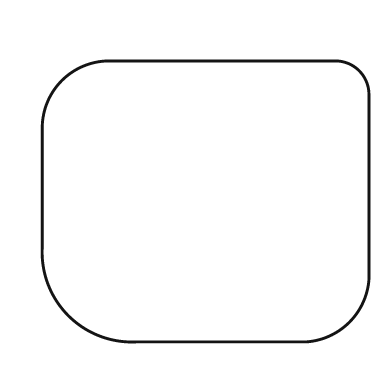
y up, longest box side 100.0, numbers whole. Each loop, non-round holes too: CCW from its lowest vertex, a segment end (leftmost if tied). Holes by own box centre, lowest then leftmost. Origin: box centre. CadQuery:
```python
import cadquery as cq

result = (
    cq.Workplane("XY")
    .moveTo(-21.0, -43.0)
    .lineTo(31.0, -43.0)
    .threePointArc((44.0, -37.0), (50.0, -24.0))
    .lineTo(50.0, 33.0)
    .threePointArc((47.0, 40.0), (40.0, 43.0))
    .lineTo(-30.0, 43.0)
    .threePointArc((-44.0, 37.0), (-50.0, 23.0))
    .lineTo(-50.0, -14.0)
    .threePointArc((-42.0, -35.0), (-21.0, -43.0))
    .close()
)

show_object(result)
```